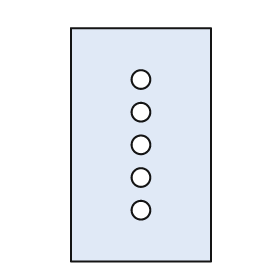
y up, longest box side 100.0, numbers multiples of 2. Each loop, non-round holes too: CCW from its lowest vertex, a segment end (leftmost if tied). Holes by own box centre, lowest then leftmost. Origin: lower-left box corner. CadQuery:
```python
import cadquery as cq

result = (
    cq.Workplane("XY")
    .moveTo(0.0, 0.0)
    .lineTo(60.0, 0.0)
    .lineTo(60.0, 100.0)
    .lineTo(0.0, 100.0)
    .close()
    .moveTo(30.0, 22.0)
    .circle(4.0)
    .moveTo(30.0, 36.0)
    .circle(4.0)
    .moveTo(30.0, 50.0)
    .circle(4.0)
    .moveTo(30.0, 64.0)
    .circle(4.0)
    .moveTo(30.0, 78.0)
    .circle(4.0)
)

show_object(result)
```